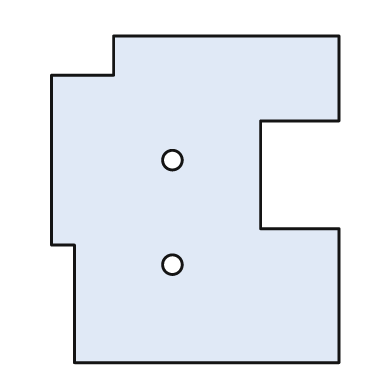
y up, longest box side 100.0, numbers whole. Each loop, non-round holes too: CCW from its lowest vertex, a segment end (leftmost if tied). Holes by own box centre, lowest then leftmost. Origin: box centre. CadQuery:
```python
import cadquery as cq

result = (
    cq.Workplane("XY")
    .moveTo(-37.0, -50.0)
    .lineTo(44.0, -50.0)
    .lineTo(44.0, -9.0)
    .lineTo(20.0, -9.0)
    .lineTo(20.0, 24.0)
    .lineTo(44.0, 24.0)
    .lineTo(44.0, 50.0)
    .lineTo(-25.0, 50.0)
    .lineTo(-25.0, 38.0)
    .lineTo(-44.0, 38.0)
    .lineTo(-44.0, -14.0)
    .lineTo(-37.0, -14.0)
    .close()
    .moveTo(-7.0, -20.0)
    .circle(3.0)
    .moveTo(-7.0, 12.0)
    .circle(3.0)
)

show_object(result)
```